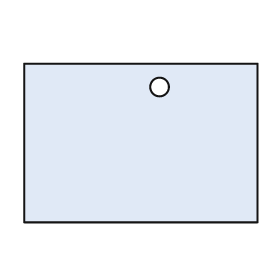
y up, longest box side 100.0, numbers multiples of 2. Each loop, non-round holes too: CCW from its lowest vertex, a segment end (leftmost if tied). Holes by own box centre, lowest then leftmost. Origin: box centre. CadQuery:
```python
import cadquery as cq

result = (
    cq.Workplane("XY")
    .moveTo(-50.0, -34.0)
    .lineTo(50.0, -34.0)
    .lineTo(50.0, 34.0)
    .lineTo(-50.0, 34.0)
    .close()
    .moveTo(8.0, 24.0)
    .circle(4.0)
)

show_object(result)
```